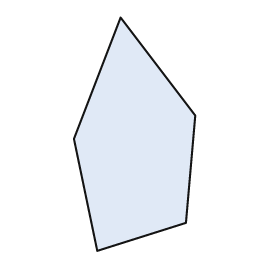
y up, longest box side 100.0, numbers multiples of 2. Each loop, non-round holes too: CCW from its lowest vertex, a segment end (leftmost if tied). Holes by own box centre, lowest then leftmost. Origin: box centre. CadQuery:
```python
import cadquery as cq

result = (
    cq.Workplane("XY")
    .moveTo(-16.0, -50.0)
    .lineTo(22.0, -38.0)
    .lineTo(26.0, 8.0)
    .lineTo(-6.0, 50.0)
    .lineTo(-26.0, -2.0)
    .close()
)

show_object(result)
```